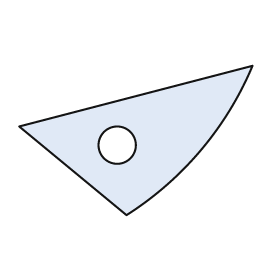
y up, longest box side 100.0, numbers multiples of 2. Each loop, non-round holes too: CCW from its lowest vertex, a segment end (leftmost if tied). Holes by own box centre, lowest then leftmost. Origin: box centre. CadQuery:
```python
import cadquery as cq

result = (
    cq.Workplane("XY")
    .moveTo(-4.0, -32.0)
    .threePointArc((28.0, -4.0), (50.0, 32.0))
    .lineTo(-50.0, 6.0)
    .close()
    .moveTo(-8.0, -2.0)
    .circle(8.0)
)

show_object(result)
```